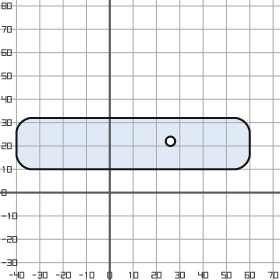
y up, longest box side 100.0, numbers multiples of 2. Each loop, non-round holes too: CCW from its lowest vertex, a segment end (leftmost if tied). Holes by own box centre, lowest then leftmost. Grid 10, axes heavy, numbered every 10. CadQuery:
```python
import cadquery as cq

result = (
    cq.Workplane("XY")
    .moveTo(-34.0, 10.0)
    .lineTo(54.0, 10.0)
    .threePointArc((58.0, 12.0), (60.0, 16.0))
    .lineTo(60.0, 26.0)
    .threePointArc((58.0, 30.0), (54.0, 32.0))
    .lineTo(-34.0, 32.0)
    .threePointArc((-38.0, 30.0), (-40.0, 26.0))
    .lineTo(-40.0, 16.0)
    .threePointArc((-38.0, 12.0), (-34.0, 10.0))
    .close()
    .moveTo(26.0, 22.0)
    .circle(2.0)
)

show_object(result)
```